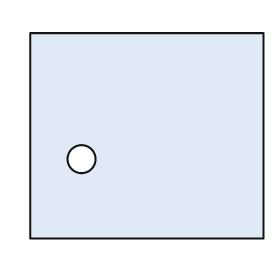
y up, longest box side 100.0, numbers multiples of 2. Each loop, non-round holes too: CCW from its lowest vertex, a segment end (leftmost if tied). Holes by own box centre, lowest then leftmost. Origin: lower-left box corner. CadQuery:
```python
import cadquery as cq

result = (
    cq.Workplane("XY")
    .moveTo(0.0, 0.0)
    .lineTo(100.0, 0.0)
    .lineTo(100.0, 88.0)
    .lineTo(0.0, 88.0)
    .close()
    .moveTo(22.0, 34.0)
    .circle(6.0)
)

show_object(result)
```